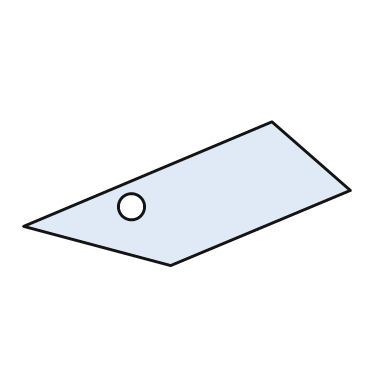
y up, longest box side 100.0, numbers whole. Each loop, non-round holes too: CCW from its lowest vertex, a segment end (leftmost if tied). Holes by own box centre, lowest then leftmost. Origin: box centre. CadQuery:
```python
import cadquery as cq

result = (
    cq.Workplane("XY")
    .moveTo(-5.0, -22.0)
    .lineTo(50.0, 1.0)
    .lineTo(26.0, 22.0)
    .lineTo(-50.0, -10.0)
    .close()
    .moveTo(-17.0, -4.0)
    .circle(4.0)
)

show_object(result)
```